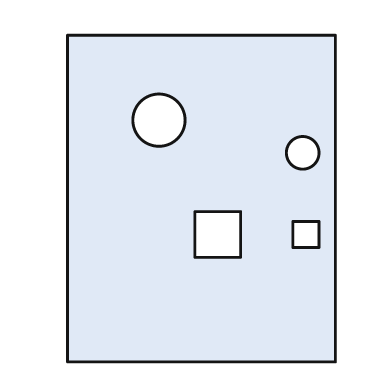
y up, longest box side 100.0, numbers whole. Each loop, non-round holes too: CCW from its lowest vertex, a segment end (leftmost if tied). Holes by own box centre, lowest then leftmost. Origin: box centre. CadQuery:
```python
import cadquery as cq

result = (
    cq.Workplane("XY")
    .moveTo(-41.0, -50.0)
    .lineTo(41.0, -50.0)
    .lineTo(41.0, 50.0)
    .lineTo(-41.0, 50.0)
    .close()
    .moveTo(-2.0, -18.0)
    .lineTo(12.0, -18.0)
    .lineTo(12.0, -4.0)
    .lineTo(-2.0, -4.0)
    .close()
    .moveTo(28.0, -15.0)
    .lineTo(36.0, -15.0)
    .lineTo(36.0, -7.0)
    .lineTo(28.0, -7.0)
    .close()
    .moveTo(31.0, 14.0)
    .circle(5.0)
    .moveTo(-13.0, 24.0)
    .circle(8.0)
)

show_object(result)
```